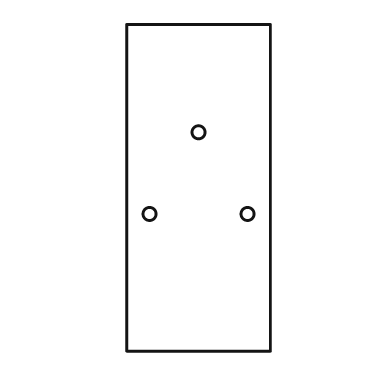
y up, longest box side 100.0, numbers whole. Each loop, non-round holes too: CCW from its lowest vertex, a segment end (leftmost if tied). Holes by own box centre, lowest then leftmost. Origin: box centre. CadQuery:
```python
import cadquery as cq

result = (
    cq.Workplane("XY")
    .moveTo(-22.0, -50.0)
    .lineTo(22.0, -50.0)
    .lineTo(22.0, 50.0)
    .lineTo(-22.0, 50.0)
    .close()
    .moveTo(-15.0, -8.0)
    .circle(2.0)
    .moveTo(15.0, -8.0)
    .circle(2.0)
    .moveTo(0.0, 17.0)
    .circle(2.0)
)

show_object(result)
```